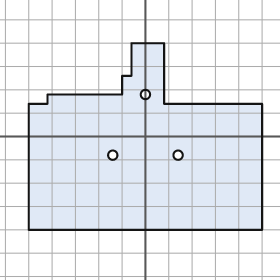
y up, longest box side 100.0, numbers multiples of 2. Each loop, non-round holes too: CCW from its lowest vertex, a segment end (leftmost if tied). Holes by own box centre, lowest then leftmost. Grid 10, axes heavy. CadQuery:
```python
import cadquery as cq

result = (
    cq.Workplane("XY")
    .moveTo(-50.0, -40.0)
    .lineTo(50.0, -40.0)
    .lineTo(50.0, 14.0)
    .lineTo(8.0, 14.0)
    .lineTo(8.0, 40.0)
    .lineTo(-6.0, 40.0)
    .lineTo(-6.0, 26.0)
    .lineTo(-10.0, 26.0)
    .lineTo(-10.0, 18.0)
    .lineTo(-42.0, 18.0)
    .lineTo(-42.0, 14.0)
    .lineTo(-50.0, 14.0)
    .close()
    .moveTo(-14.0, -8.0)
    .circle(2.0)
    .moveTo(14.0, -8.0)
    .circle(2.0)
    .moveTo(0.0, 18.0)
    .circle(2.0)
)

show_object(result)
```